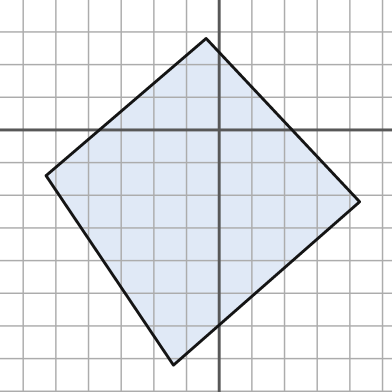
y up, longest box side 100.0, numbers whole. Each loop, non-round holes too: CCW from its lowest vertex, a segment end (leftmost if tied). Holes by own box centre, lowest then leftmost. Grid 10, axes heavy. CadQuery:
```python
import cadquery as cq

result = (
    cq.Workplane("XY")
    .moveTo(-14.0, -72.0)
    .lineTo(43.0, -22.0)
    .lineTo(-4.0, 28.0)
    .lineTo(-53.0, -14.0)
    .close()
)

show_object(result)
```